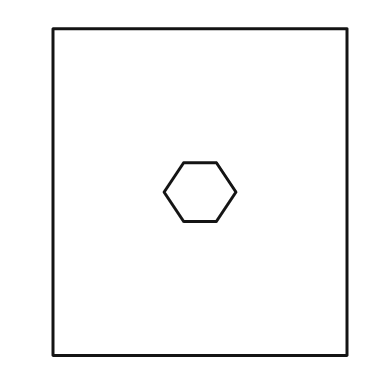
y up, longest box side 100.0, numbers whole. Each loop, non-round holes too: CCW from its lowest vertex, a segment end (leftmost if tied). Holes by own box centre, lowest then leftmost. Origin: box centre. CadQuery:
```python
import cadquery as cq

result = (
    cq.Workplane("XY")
    .moveTo(-45.0, -50.0)
    .lineTo(45.0, -50.0)
    .lineTo(45.0, 50.0)
    .lineTo(-45.0, 50.0)
    .close()
    .moveTo(-5.0, -9.0)
    .lineTo(5.0, -9.0)
    .lineTo(11.0, 0.0)
    .lineTo(5.0, 9.0)
    .lineTo(-5.0, 9.0)
    .lineTo(-11.0, 0.0)
    .close()
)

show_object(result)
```